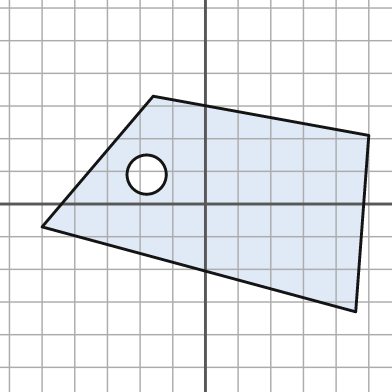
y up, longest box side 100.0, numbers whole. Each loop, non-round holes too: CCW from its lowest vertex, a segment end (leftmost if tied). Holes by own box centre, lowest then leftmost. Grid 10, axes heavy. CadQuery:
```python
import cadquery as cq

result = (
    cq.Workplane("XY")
    .moveTo(46.0, -33.0)
    .lineTo(50.0, 21.0)
    .lineTo(-16.0, 33.0)
    .lineTo(-50.0, -7.0)
    .close()
    .moveTo(-18.0, 9.0)
    .circle(6.0)
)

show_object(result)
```